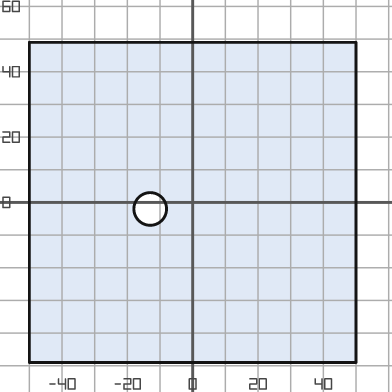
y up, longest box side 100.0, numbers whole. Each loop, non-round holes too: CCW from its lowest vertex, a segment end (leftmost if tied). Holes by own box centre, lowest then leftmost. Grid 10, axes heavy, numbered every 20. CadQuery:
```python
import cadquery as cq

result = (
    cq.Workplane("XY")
    .moveTo(-50.0, -49.0)
    .lineTo(50.0, -49.0)
    .lineTo(50.0, 49.0)
    .lineTo(-50.0, 49.0)
    .close()
    .moveTo(-13.0, -2.0)
    .circle(5.0)
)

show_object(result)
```